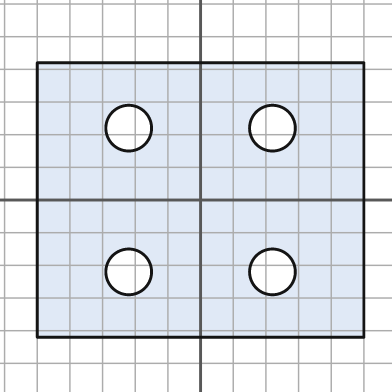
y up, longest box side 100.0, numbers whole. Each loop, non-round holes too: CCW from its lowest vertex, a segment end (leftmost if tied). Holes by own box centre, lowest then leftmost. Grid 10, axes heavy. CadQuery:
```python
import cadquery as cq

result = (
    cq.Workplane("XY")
    .moveTo(-50.0, -42.0)
    .lineTo(50.0, -42.0)
    .lineTo(50.0, 42.0)
    .lineTo(-50.0, 42.0)
    .close()
    .moveTo(-22.0, -22.0)
    .circle(7.0)
    .moveTo(22.0, -22.0)
    .circle(7.0)
    .moveTo(-22.0, 22.0)
    .circle(7.0)
    .moveTo(22.0, 22.0)
    .circle(7.0)
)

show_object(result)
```